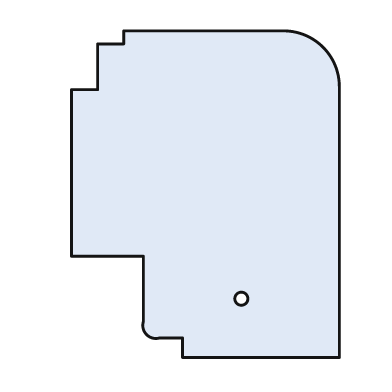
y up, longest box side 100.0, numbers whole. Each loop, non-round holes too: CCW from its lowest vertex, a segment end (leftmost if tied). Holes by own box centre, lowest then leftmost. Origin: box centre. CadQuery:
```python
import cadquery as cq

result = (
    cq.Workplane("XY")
    .moveTo(-7.0, -50.0)
    .lineTo(41.0, -50.0)
    .lineTo(41.0, 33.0)
    .threePointArc((36.0, 45.0), (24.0, 50.0))
    .lineTo(-25.0, 50.0)
    .lineTo(-25.0, 46.0)
    .lineTo(-33.0, 46.0)
    .lineTo(-33.0, 32.0)
    .lineTo(-41.0, 32.0)
    .lineTo(-41.0, -19.0)
    .lineTo(-19.0, -19.0)
    .lineTo(-19.0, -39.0)
    .threePointArc((-18.0, -43.0), (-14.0, -44.0))
    .lineTo(-7.0, -44.0)
    .close()
    .moveTo(11.0, -32.0)
    .circle(2.0)
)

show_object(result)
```